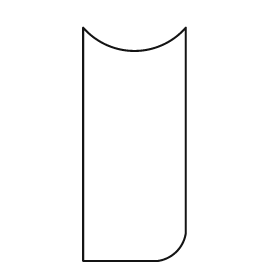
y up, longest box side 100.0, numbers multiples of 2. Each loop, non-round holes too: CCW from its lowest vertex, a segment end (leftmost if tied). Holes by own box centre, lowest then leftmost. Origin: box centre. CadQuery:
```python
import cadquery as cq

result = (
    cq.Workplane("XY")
    .moveTo(-22.0, -50.0)
    .lineTo(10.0, -50.0)
    .threePointArc((18.0, -46.0), (22.0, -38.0))
    .lineTo(22.0, 50.0)
    .threePointArc((0.0, 40.0), (-22.0, 50.0))
    .close()
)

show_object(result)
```